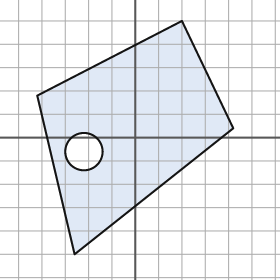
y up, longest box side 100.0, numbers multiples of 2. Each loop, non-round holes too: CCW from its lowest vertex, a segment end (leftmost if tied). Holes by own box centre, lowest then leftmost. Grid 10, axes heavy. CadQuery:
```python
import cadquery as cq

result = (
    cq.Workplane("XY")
    .moveTo(-26.0, -50.0)
    .lineTo(42.0, 4.0)
    .lineTo(20.0, 50.0)
    .lineTo(-42.0, 18.0)
    .close()
    .moveTo(-22.0, -6.0)
    .circle(8.0)
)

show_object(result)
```